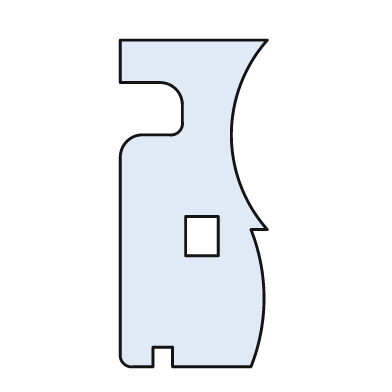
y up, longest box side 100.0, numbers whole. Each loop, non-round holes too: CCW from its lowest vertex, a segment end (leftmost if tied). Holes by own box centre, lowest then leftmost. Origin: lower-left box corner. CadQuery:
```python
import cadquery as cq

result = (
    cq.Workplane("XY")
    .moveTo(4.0, 0.0)
    .lineTo(10.0, 0.0)
    .lineTo(10.0, 6.0)
    .lineTo(16.0, 6.0)
    .lineTo(16.0, 0.0)
    .lineTo(40.0, 0.0)
    .threePointArc((44.0, 21.0), (40.0, 42.0))
    .lineTo(45.0, 42.0)
    .threePointArc((34.0, 71.0), (45.0, 100.0))
    .lineTo(0.0, 100.0)
    .lineTo(0.0, 87.0)
    .lineTo(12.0, 87.0)
    .threePointArc((17.0, 85.0), (19.0, 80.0))
    .lineTo(19.0, 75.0)
    .threePointArc((18.0, 72.0), (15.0, 71.0))
    .lineTo(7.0, 71.0)
    .threePointArc((2.0, 69.0), (0.0, 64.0))
    .lineTo(0.0, 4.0)
    .threePointArc((1.0, 1.0), (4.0, 0.0))
    .close()
    .moveTo(20.0, 34.0)
    .lineTo(30.0, 34.0)
    .lineTo(30.0, 46.0)
    .lineTo(20.0, 46.0)
    .close()
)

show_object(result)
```